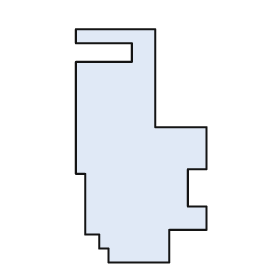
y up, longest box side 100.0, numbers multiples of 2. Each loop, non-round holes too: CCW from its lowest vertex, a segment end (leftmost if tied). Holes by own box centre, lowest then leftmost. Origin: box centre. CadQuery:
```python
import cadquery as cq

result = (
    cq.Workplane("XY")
    .moveTo(-14.0, -50.0)
    .lineTo(12.0, -50.0)
    .lineTo(12.0, -36.0)
    .lineTo(28.0, -36.0)
    .lineTo(28.0, -26.0)
    .lineTo(20.0, -26.0)
    .lineTo(20.0, -10.0)
    .lineTo(28.0, -10.0)
    .lineTo(28.0, 8.0)
    .lineTo(6.0, 8.0)
    .lineTo(6.0, 50.0)
    .lineTo(-28.0, 50.0)
    .lineTo(-28.0, 44.0)
    .lineTo(-4.0, 44.0)
    .lineTo(-4.0, 36.0)
    .lineTo(-28.0, 36.0)
    .lineTo(-28.0, -12.0)
    .lineTo(-24.0, -12.0)
    .lineTo(-24.0, -38.0)
    .lineTo(-18.0, -38.0)
    .lineTo(-18.0, -44.0)
    .lineTo(-14.0, -44.0)
    .close()
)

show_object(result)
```